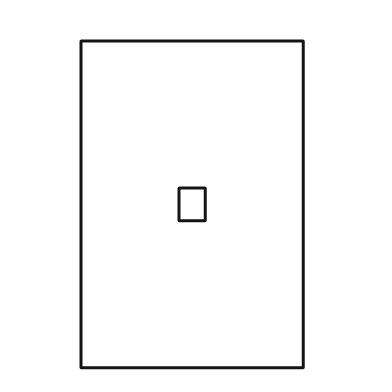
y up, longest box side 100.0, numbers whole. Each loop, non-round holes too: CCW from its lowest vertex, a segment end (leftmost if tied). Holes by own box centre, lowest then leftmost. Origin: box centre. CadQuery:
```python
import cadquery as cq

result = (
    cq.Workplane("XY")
    .moveTo(-34.0, -50.0)
    .lineTo(34.0, -50.0)
    .lineTo(34.0, 50.0)
    .lineTo(-34.0, 50.0)
    .close()
    .moveTo(-4.0, -5.0)
    .lineTo(4.0, -5.0)
    .lineTo(4.0, 5.0)
    .lineTo(-4.0, 5.0)
    .close()
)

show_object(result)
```